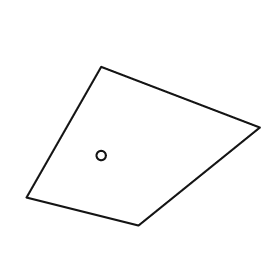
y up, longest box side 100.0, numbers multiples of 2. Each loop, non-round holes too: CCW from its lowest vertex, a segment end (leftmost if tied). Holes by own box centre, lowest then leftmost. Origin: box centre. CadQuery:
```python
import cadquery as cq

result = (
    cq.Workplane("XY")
    .moveTo(-2.0, -34.0)
    .lineTo(50.0, 8.0)
    .lineTo(-18.0, 34.0)
    .lineTo(-50.0, -22.0)
    .close()
    .moveTo(-18.0, -4.0)
    .circle(2.0)
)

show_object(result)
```